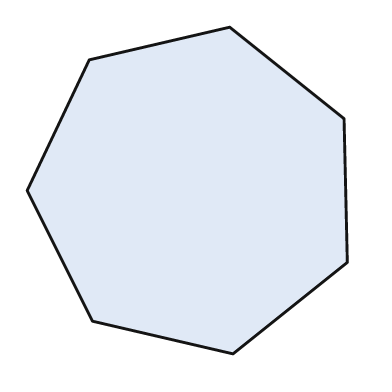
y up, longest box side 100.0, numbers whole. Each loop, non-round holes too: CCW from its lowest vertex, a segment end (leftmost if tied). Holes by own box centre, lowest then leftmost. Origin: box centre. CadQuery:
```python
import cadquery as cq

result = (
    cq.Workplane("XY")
    .moveTo(14.0, -50.0)
    .lineTo(49.0, -22.0)
    .lineTo(48.0, 22.0)
    .lineTo(13.0, 50.0)
    .lineTo(-30.0, 40.0)
    .lineTo(-49.0, 0.0)
    .lineTo(-29.0, -40.0)
    .close()
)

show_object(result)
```